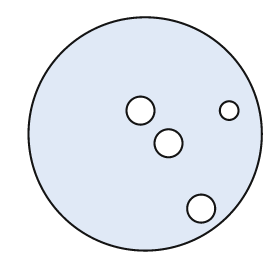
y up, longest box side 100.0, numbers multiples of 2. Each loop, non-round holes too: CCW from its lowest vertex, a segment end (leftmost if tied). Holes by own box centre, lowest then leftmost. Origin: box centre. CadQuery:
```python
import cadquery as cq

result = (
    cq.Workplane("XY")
    .moveTo(0.0, 0.0)
    .circle(50.0)
    .moveTo(24.0, -32.0)
    .circle(6.0)
    .moveTo(10.0, -4.0)
    .circle(6.0)
    .moveTo(-2.0, 10.0)
    .circle(6.0)
    .moveTo(36.0, 10.0)
    .circle(4.0)
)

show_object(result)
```